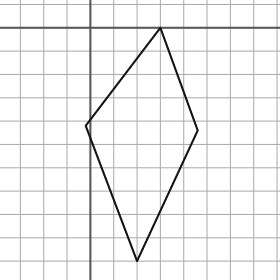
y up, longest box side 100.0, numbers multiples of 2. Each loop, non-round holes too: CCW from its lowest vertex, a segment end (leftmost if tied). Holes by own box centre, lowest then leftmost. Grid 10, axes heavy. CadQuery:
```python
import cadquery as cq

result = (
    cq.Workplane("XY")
    .moveTo(20.0, -100.0)
    .lineTo(46.0, -44.0)
    .lineTo(30.0, 0.0)
    .lineTo(-2.0, -42.0)
    .close()
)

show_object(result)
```